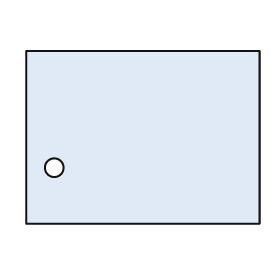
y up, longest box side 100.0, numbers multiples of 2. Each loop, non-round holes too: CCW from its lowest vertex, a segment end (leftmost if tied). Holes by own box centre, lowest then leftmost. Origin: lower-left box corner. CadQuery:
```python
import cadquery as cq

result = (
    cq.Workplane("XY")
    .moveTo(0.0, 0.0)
    .lineTo(100.0, 0.0)
    .lineTo(100.0, 74.0)
    .lineTo(0.0, 74.0)
    .close()
    .moveTo(12.0, 24.0)
    .circle(4.0)
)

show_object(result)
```